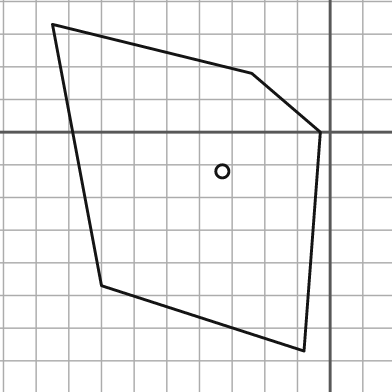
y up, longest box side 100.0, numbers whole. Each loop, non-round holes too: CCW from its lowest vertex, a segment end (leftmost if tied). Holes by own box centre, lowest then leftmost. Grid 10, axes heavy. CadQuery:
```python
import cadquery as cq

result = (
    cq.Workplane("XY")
    .moveTo(-8.0, -67.0)
    .lineTo(-3.0, 0.0)
    .lineTo(-24.0, 18.0)
    .lineTo(-85.0, 33.0)
    .lineTo(-70.0, -47.0)
    .close()
    .moveTo(-33.0, -12.0)
    .circle(2.0)
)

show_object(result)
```